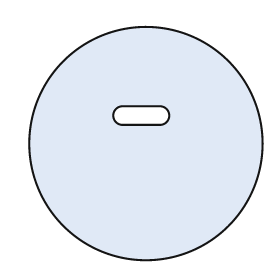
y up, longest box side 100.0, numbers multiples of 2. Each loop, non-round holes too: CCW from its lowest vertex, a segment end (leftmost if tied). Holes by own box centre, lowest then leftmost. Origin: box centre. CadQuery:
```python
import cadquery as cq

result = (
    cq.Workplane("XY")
    .moveTo(0.0, 0.0)
    .circle(50.0)
    .moveTo(-10.0, 8.0)
    .lineTo(6.0, 8.0)
    .threePointArc((10.0, 12.0), (6.0, 16.0))
    .lineTo(-10.0, 16.0)
    .threePointArc((-14.0, 12.0), (-10.0, 8.0))
    .close()
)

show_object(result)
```